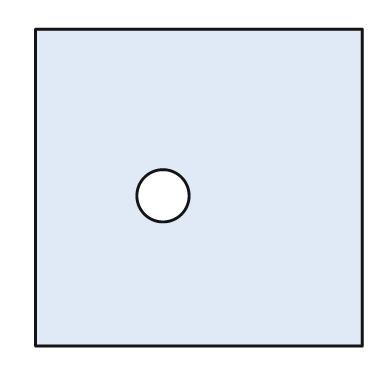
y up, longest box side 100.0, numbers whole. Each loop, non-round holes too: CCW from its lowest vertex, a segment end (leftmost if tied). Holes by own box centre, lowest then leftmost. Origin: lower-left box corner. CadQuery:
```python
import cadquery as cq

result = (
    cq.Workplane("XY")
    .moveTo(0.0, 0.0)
    .lineTo(100.0, 0.0)
    .lineTo(100.0, 97.0)
    .lineTo(0.0, 97.0)
    .close()
    .moveTo(39.0, 46.0)
    .circle(8.0)
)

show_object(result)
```